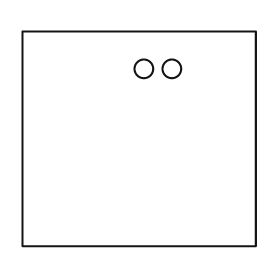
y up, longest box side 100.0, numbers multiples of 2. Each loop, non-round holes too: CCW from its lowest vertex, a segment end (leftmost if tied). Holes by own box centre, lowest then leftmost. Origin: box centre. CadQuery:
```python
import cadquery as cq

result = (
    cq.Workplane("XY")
    .moveTo(-50.0, -46.0)
    .lineTo(50.0, -46.0)
    .lineTo(50.0, 46.0)
    .lineTo(-50.0, 46.0)
    .close()
    .moveTo(2.0, 30.0)
    .circle(4.0)
    .moveTo(14.0, 30.0)
    .circle(4.0)
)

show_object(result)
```